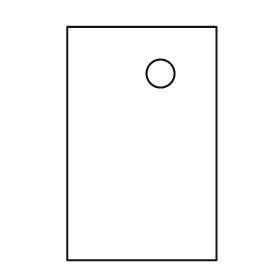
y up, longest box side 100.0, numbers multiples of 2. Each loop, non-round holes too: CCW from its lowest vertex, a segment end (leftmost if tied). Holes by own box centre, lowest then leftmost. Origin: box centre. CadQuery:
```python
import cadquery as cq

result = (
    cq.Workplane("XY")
    .moveTo(-32.0, -50.0)
    .lineTo(32.0, -50.0)
    .lineTo(32.0, 50.0)
    .lineTo(-32.0, 50.0)
    .close()
    .moveTo(8.0, 30.0)
    .circle(6.0)
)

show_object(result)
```